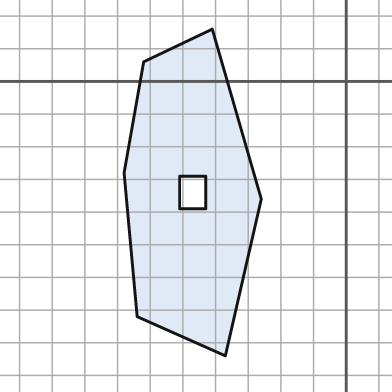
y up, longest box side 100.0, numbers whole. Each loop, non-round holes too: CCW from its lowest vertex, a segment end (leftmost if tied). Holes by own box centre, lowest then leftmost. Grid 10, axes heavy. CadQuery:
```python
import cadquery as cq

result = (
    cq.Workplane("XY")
    .moveTo(-37.0, -84.0)
    .lineTo(-26.0, -36.0)
    .lineTo(-41.0, 16.0)
    .lineTo(-62.0, 6.0)
    .lineTo(-68.0, -28.0)
    .lineTo(-64.0, -72.0)
    .close()
    .moveTo(-51.0, -39.0)
    .lineTo(-43.0, -39.0)
    .lineTo(-43.0, -29.0)
    .lineTo(-51.0, -29.0)
    .close()
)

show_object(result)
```